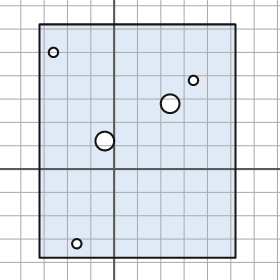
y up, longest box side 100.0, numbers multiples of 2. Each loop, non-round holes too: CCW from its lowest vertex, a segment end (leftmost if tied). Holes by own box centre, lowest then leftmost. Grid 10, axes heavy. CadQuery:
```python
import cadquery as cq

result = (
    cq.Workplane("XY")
    .moveTo(-32.0, -38.0)
    .lineTo(52.0, -38.0)
    .lineTo(52.0, 62.0)
    .lineTo(-32.0, 62.0)
    .close()
    .moveTo(-16.0, -32.0)
    .circle(2.0)
    .moveTo(-4.0, 12.0)
    .circle(4.0)
    .moveTo(24.0, 28.0)
    .circle(4.0)
    .moveTo(34.0, 38.0)
    .circle(2.0)
    .moveTo(-26.0, 50.0)
    .circle(2.0)
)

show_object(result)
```